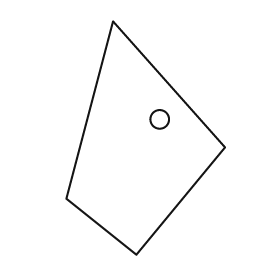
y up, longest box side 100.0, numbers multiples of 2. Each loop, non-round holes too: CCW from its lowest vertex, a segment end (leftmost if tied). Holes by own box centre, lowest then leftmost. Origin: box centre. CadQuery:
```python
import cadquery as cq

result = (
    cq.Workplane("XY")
    .moveTo(-4.0, -50.0)
    .lineTo(34.0, -4.0)
    .lineTo(-14.0, 50.0)
    .lineTo(-34.0, -26.0)
    .close()
    .moveTo(6.0, 8.0)
    .circle(4.0)
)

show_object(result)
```